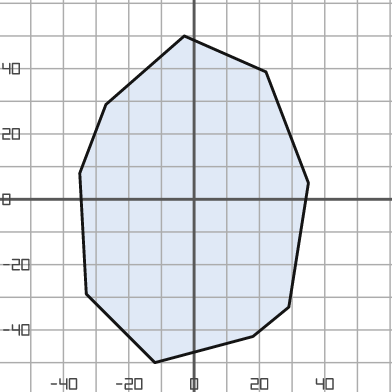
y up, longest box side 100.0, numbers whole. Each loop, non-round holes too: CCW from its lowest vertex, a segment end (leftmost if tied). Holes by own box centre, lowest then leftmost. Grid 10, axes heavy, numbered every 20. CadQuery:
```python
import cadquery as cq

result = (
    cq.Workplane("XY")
    .moveTo(-12.0, -50.0)
    .lineTo(18.0, -42.0)
    .lineTo(29.0, -33.0)
    .lineTo(35.0, 5.0)
    .lineTo(22.0, 39.0)
    .lineTo(-3.0, 50.0)
    .lineTo(-27.0, 29.0)
    .lineTo(-35.0, 8.0)
    .lineTo(-33.0, -29.0)
    .close()
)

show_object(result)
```